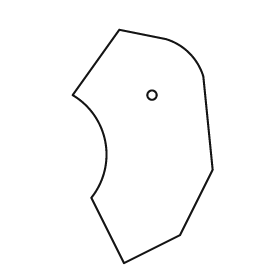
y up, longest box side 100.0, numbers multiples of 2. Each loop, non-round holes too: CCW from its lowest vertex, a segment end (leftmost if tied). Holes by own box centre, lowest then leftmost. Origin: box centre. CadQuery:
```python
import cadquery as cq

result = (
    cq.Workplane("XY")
    .moveTo(-8.0, -50.0)
    .lineTo(16.0, -38.0)
    .lineTo(30.0, -10.0)
    .lineTo(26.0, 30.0)
    .threePointArc((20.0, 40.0), (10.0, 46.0))
    .lineTo(-10.0, 50.0)
    .lineTo(-30.0, 22.0)
    .threePointArc((-16.0, 2.0), (-22.0, -22.0))
    .close()
    .moveTo(4.0, 22.0)
    .circle(2.0)
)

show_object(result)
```